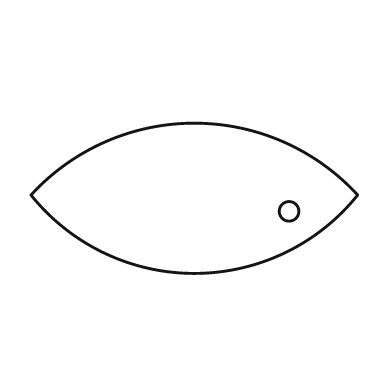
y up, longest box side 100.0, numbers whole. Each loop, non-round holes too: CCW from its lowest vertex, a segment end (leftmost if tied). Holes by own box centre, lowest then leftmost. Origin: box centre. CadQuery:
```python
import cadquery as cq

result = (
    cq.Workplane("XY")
    .moveTo(-50.0, 1.0)
    .threePointArc((0.0, -23.0), (50.0, 1.0))
    .threePointArc((0.0, 23.0), (-50.0, 1.0))
    .close()
    .moveTo(29.0, -4.0)
    .circle(3.0)
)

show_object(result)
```